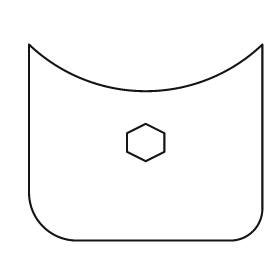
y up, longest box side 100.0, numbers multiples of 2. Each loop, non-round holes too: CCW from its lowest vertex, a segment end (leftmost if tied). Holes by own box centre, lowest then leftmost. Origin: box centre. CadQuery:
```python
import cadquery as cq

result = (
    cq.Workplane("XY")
    .moveTo(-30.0, -42.0)
    .lineTo(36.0, -42.0)
    .threePointArc((46.0, -38.0), (50.0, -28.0))
    .lineTo(50.0, 42.0)
    .threePointArc((0.0, 22.0), (-50.0, 42.0))
    .lineTo(-50.0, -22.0)
    .threePointArc((-44.0, -36.0), (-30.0, -42.0))
    .close()
    .moveTo(0.0, -8.0)
    .lineTo(8.0, -4.0)
    .lineTo(8.0, 4.0)
    .lineTo(0.0, 8.0)
    .lineTo(-8.0, 4.0)
    .lineTo(-8.0, -4.0)
    .close()
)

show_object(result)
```